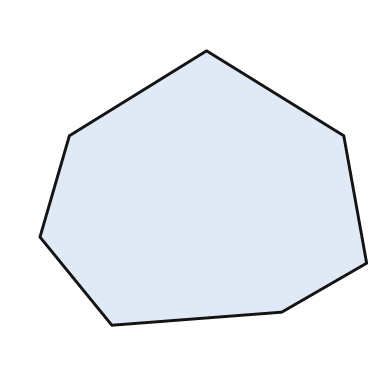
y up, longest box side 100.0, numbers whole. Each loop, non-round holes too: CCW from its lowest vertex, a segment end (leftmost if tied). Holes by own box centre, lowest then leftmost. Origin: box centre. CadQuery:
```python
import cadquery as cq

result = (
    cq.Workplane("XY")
    .moveTo(-28.0, -42.0)
    .lineTo(24.0, -38.0)
    .lineTo(50.0, -23.0)
    .lineTo(43.0, 16.0)
    .lineTo(1.0, 42.0)
    .lineTo(-41.0, 16.0)
    .lineTo(-50.0, -15.0)
    .close()
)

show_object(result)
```